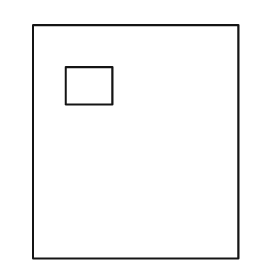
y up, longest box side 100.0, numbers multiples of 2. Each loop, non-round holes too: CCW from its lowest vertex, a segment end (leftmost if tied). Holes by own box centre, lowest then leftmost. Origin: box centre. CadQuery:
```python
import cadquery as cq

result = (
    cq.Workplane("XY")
    .moveTo(-44.0, -50.0)
    .lineTo(44.0, -50.0)
    .lineTo(44.0, 50.0)
    .lineTo(-44.0, 50.0)
    .close()
    .moveTo(-30.0, 16.0)
    .lineTo(-10.0, 16.0)
    .lineTo(-10.0, 32.0)
    .lineTo(-30.0, 32.0)
    .close()
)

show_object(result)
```